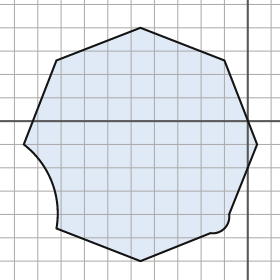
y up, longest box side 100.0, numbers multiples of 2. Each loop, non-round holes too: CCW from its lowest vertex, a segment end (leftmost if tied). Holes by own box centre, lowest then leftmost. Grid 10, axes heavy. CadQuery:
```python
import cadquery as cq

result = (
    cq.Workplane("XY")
    .moveTo(-46.0, -60.0)
    .lineTo(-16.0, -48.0)
    .threePointArc((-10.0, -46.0), (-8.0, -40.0))
    .lineTo(4.0, -10.0)
    .lineTo(-10.0, 26.0)
    .lineTo(-46.0, 40.0)
    .lineTo(-82.0, 26.0)
    .lineTo(-96.0, -10.0)
    .threePointArc((-84.0, -26.0), (-82.0, -46.0))
    .close()
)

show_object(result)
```